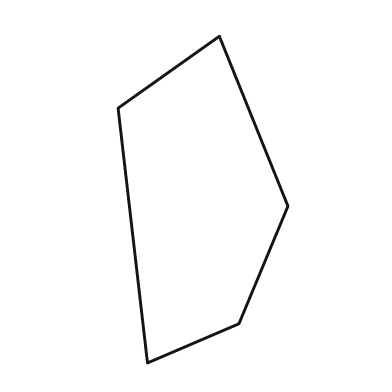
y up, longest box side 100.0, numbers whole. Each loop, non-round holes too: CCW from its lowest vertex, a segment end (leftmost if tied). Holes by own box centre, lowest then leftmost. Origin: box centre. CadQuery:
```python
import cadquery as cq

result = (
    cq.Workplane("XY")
    .moveTo(-17.0, -50.0)
    .lineTo(11.0, -38.0)
    .lineTo(26.0, -2.0)
    .lineTo(5.0, 50.0)
    .lineTo(-26.0, 28.0)
    .close()
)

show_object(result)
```